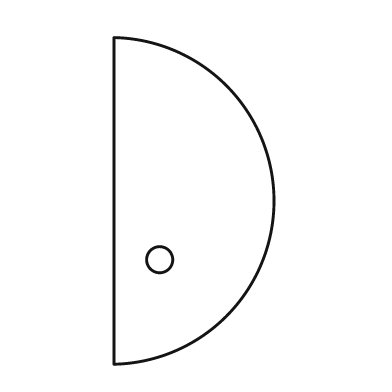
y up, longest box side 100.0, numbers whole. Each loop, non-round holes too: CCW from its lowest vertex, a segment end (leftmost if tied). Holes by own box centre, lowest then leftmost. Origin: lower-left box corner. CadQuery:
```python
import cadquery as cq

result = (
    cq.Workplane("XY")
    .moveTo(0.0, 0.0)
    .threePointArc((49.0, 50.0), (0.0, 100.0))
    .close()
    .moveTo(14.0, 32.0)
    .circle(4.0)
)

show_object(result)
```